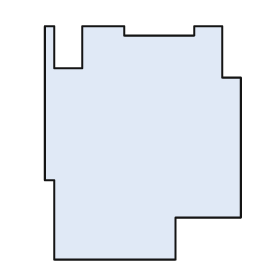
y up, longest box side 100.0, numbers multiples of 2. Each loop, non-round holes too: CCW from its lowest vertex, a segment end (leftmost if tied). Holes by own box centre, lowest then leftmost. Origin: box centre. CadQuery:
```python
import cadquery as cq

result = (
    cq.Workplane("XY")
    .moveTo(-38.0, -50.0)
    .lineTo(14.0, -50.0)
    .lineTo(14.0, -32.0)
    .lineTo(42.0, -32.0)
    .lineTo(42.0, 28.0)
    .lineTo(34.0, 28.0)
    .lineTo(34.0, 50.0)
    .lineTo(22.0, 50.0)
    .lineTo(22.0, 46.0)
    .lineTo(-8.0, 46.0)
    .lineTo(-8.0, 50.0)
    .lineTo(-26.0, 50.0)
    .lineTo(-26.0, 32.0)
    .lineTo(-38.0, 32.0)
    .lineTo(-38.0, 50.0)
    .lineTo(-42.0, 50.0)
    .lineTo(-42.0, -16.0)
    .lineTo(-38.0, -16.0)
    .close()
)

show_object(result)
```